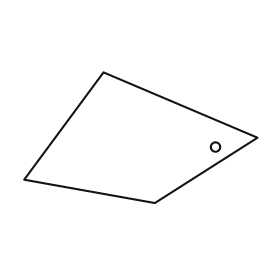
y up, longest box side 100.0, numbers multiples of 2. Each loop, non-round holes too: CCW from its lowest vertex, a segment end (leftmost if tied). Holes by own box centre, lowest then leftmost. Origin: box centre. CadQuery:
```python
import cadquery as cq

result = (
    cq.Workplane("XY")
    .moveTo(6.0, -28.0)
    .lineTo(50.0, 0.0)
    .lineTo(-16.0, 28.0)
    .lineTo(-50.0, -18.0)
    .close()
    .moveTo(32.0, -4.0)
    .circle(2.0)
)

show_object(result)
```